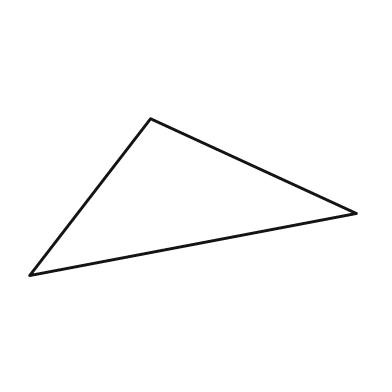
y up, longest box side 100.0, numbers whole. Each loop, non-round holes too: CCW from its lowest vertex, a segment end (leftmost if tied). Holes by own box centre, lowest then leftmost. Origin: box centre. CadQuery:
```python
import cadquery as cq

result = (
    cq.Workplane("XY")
    .moveTo(-50.0, -24.0)
    .lineTo(50.0, -5.0)
    .lineTo(-13.0, 24.0)
    .close()
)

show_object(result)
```